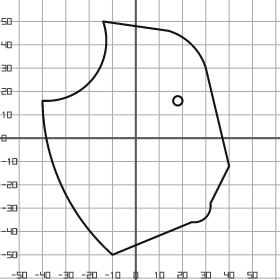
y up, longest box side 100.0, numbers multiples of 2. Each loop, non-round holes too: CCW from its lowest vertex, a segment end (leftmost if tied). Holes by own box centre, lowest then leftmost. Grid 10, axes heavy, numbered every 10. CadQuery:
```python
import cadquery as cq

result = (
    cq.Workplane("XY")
    .moveTo(-10.0, -50.0)
    .lineTo(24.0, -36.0)
    .threePointArc((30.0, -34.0), (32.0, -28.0))
    .lineTo(40.0, -12.0)
    .lineTo(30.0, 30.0)
    .threePointArc((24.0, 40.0), (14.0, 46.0))
    .lineTo(-14.0, 50.0)
    .threePointArc((-18.0, 26.0), (-40.0, 16.0))
    .threePointArc((-32.0, -20.0), (-10.0, -50.0))
    .close()
    .moveTo(18.0, 16.0)
    .circle(2.0)
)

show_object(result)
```